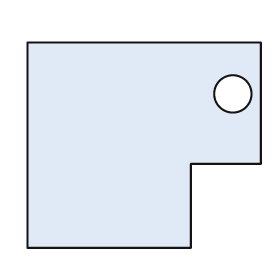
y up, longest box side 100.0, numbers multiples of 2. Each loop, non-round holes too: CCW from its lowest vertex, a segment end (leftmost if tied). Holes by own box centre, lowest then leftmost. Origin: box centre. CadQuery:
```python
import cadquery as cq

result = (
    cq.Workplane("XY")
    .moveTo(-50.0, -44.0)
    .lineTo(20.0, -44.0)
    .lineTo(20.0, -8.0)
    .lineTo(50.0, -8.0)
    .lineTo(50.0, 44.0)
    .lineTo(-50.0, 44.0)
    .close()
    .moveTo(38.0, 22.0)
    .circle(8.0)
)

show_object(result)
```